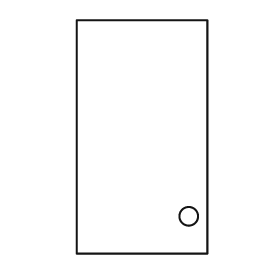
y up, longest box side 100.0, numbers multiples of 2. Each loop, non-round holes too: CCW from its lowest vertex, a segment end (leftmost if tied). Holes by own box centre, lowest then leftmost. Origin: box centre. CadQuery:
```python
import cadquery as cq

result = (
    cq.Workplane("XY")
    .moveTo(-28.0, -50.0)
    .lineTo(28.0, -50.0)
    .lineTo(28.0, 50.0)
    .lineTo(-28.0, 50.0)
    .close()
    .moveTo(20.0, -34.0)
    .circle(4.0)
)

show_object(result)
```